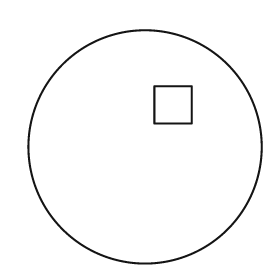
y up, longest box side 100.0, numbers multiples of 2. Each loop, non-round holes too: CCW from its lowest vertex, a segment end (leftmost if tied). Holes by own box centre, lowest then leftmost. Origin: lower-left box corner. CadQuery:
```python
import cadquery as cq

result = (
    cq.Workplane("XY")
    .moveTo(50.0, 50.0)
    .circle(50.0)
    .moveTo(54.0, 60.0)
    .lineTo(70.0, 60.0)
    .lineTo(70.0, 76.0)
    .lineTo(54.0, 76.0)
    .close()
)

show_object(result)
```